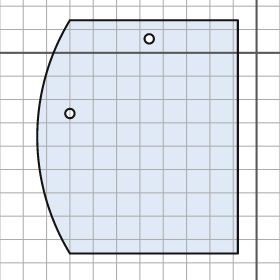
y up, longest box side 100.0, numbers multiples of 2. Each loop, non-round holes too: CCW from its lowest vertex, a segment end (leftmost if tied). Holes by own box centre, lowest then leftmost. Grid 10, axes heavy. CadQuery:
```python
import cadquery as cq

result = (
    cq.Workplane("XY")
    .moveTo(-80.0, -86.0)
    .lineTo(-8.0, -86.0)
    .lineTo(-8.0, 14.0)
    .lineTo(-80.0, 14.0)
    .threePointArc((-94.0, -36.0), (-80.0, -86.0))
    .close()
    .moveTo(-80.0, -26.0)
    .circle(2.0)
    .moveTo(-46.0, 6.0)
    .circle(2.0)
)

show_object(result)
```